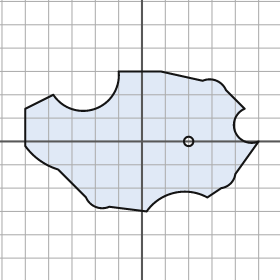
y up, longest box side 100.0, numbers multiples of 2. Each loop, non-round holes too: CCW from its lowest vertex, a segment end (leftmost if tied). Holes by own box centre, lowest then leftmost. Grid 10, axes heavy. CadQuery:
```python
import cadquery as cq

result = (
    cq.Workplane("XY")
    .moveTo(2.0, -30.0)
    .threePointArc((14.0, -22.0), (28.0, -24.0))
    .lineTo(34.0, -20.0)
    .threePointArc((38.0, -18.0), (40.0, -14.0))
    .lineTo(50.0, 0.0)
    .threePointArc((40.0, 4.0), (44.0, 14.0))
    .lineTo(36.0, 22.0)
    .threePointArc((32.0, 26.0), (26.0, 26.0))
    .lineTo(8.0, 30.0)
    .lineTo(-10.0, 30.0)
    .threePointArc((-20.0, 14.0), (-38.0, 20.0))
    .lineTo(-50.0, 14.0)
    .lineTo(-50.0, -2.0)
    .threePointArc((-44.0, -8.0), (-36.0, -12.0))
    .lineTo(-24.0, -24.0)
    .threePointArc((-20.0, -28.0), (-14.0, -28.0))
    .close()
    .moveTo(20.0, 0.0)
    .circle(2.0)
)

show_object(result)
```